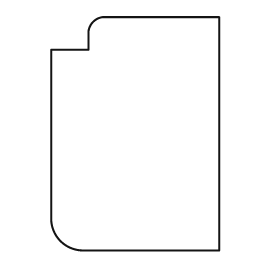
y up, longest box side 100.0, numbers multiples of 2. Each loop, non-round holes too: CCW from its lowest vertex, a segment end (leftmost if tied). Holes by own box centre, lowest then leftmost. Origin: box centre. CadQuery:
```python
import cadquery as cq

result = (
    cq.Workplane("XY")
    .moveTo(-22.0, -50.0)
    .lineTo(36.0, -50.0)
    .lineTo(36.0, 50.0)
    .lineTo(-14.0, 50.0)
    .threePointArc((-18.0, 48.0), (-20.0, 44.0))
    .lineTo(-20.0, 36.0)
    .lineTo(-36.0, 36.0)
    .lineTo(-36.0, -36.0)
    .threePointArc((-32.0, -46.0), (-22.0, -50.0))
    .close()
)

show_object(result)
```